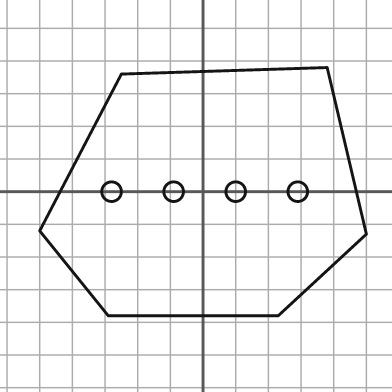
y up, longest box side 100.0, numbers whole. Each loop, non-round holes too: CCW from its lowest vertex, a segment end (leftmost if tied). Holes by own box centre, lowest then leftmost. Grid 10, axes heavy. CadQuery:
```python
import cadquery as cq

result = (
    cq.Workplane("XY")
    .moveTo(-29.0, -38.0)
    .lineTo(23.0, -38.0)
    .lineTo(50.0, -13.0)
    .lineTo(38.0, 38.0)
    .lineTo(-25.0, 36.0)
    .lineTo(-50.0, -12.0)
    .close()
    .moveTo(-28.0, 0.0)
    .circle(3.0)
    .moveTo(-9.0, 0.0)
    .circle(3.0)
    .moveTo(10.0, 0.0)
    .circle(3.0)
    .moveTo(29.0, 0.0)
    .circle(3.0)
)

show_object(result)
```